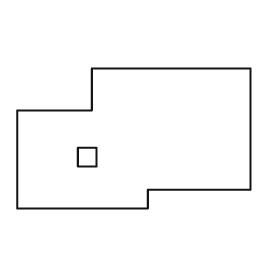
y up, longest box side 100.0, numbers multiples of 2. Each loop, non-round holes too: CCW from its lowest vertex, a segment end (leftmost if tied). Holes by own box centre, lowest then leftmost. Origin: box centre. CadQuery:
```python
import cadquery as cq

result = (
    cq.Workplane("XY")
    .moveTo(-50.0, -30.0)
    .lineTo(6.0, -30.0)
    .lineTo(6.0, -22.0)
    .lineTo(50.0, -22.0)
    .lineTo(50.0, 30.0)
    .lineTo(-18.0, 30.0)
    .lineTo(-18.0, 12.0)
    .lineTo(-50.0, 12.0)
    .close()
    .moveTo(-24.0, -12.0)
    .lineTo(-16.0, -12.0)
    .lineTo(-16.0, -4.0)
    .lineTo(-24.0, -4.0)
    .close()
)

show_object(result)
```